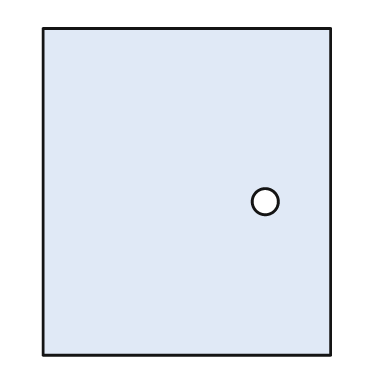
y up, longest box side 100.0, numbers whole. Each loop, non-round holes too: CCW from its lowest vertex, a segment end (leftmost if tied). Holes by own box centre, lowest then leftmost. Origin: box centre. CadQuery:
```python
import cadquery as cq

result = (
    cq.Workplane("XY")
    .moveTo(-44.0, -50.0)
    .lineTo(44.0, -50.0)
    .lineTo(44.0, 50.0)
    .lineTo(-44.0, 50.0)
    .close()
    .moveTo(24.0, -3.0)
    .circle(4.0)
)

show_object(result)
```